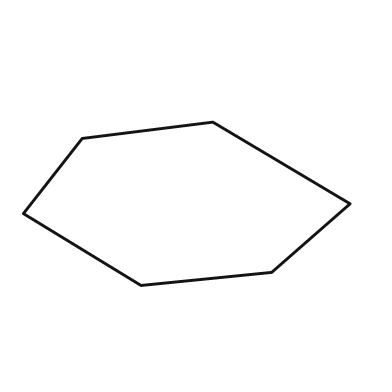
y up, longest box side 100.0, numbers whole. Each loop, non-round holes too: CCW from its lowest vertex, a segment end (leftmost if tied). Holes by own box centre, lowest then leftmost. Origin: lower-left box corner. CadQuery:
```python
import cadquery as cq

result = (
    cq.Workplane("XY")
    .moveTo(36.0, 0.0)
    .lineTo(76.0, 4.0)
    .lineTo(100.0, 25.0)
    .lineTo(58.0, 50.0)
    .lineTo(18.0, 45.0)
    .lineTo(0.0, 22.0)
    .close()
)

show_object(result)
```